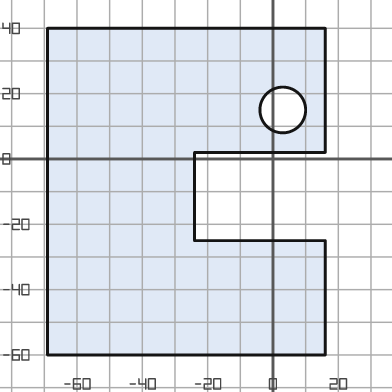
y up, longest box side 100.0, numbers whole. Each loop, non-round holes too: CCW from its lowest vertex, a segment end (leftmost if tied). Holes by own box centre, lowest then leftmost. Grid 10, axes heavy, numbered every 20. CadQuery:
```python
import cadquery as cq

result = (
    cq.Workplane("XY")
    .moveTo(-69.0, -60.0)
    .lineTo(16.0, -60.0)
    .lineTo(16.0, -25.0)
    .lineTo(-24.0, -25.0)
    .lineTo(-24.0, 2.0)
    .lineTo(16.0, 2.0)
    .lineTo(16.0, 40.0)
    .lineTo(-69.0, 40.0)
    .close()
    .moveTo(3.0, 15.0)
    .circle(7.0)
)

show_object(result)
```